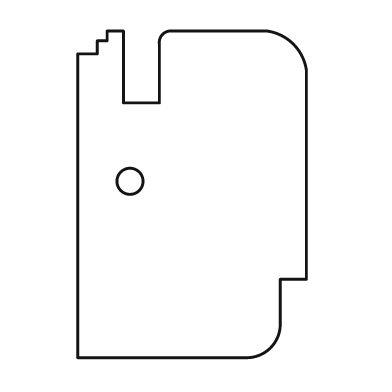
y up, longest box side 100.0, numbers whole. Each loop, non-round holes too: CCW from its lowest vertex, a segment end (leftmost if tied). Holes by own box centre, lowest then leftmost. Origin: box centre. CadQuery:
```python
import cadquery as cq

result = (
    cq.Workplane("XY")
    .moveTo(-35.0, -50.0)
    .lineTo(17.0, -50.0)
    .threePointArc((24.0, -47.0), (27.0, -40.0))
    .lineTo(27.0, -26.0)
    .lineTo(35.0, -26.0)
    .lineTo(35.0, 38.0)
    .threePointArc((31.0, 46.0), (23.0, 50.0))
    .lineTo(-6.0, 50.0)
    .threePointArc((-9.0, 49.0), (-10.0, 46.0))
    .lineTo(-10.0, 28.0)
    .lineTo(-21.0, 28.0)
    .lineTo(-21.0, 50.0)
    .lineTo(-26.0, 50.0)
    .lineTo(-26.0, 47.0)
    .lineTo(-29.0, 47.0)
    .lineTo(-29.0, 43.0)
    .lineTo(-35.0, 43.0)
    .close()
    .moveTo(-19.0, 4.0)
    .circle(4.0)
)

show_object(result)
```